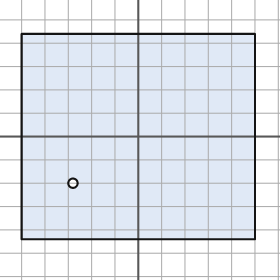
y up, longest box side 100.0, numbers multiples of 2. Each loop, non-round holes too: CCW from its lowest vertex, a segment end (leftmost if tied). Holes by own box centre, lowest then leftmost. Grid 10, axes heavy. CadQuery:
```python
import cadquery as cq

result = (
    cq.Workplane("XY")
    .moveTo(-50.0, -44.0)
    .lineTo(50.0, -44.0)
    .lineTo(50.0, 44.0)
    .lineTo(-50.0, 44.0)
    .close()
    .moveTo(-28.0, -20.0)
    .circle(2.0)
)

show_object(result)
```